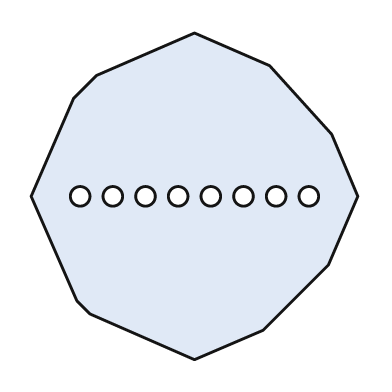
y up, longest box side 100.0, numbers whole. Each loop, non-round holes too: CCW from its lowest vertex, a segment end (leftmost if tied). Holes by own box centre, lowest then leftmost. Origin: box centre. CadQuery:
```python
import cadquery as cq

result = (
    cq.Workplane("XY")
    .moveTo(0.0, -50.0)
    .lineTo(21.0, -41.0)
    .lineTo(41.0, -21.0)
    .lineTo(50.0, 0.0)
    .lineTo(42.0, 19.0)
    .lineTo(23.0, 40.0)
    .lineTo(0.0, 50.0)
    .lineTo(-30.0, 37.0)
    .lineTo(-37.0, 30.0)
    .lineTo(-50.0, 0.0)
    .lineTo(-36.0, -32.0)
    .lineTo(-32.0, -36.0)
    .close()
    .moveTo(-35.0, 0.0)
    .circle(3.0)
    .moveTo(-25.0, 0.0)
    .circle(3.0)
    .moveTo(-15.0, 0.0)
    .circle(3.0)
    .moveTo(-5.0, 0.0)
    .circle(3.0)
    .moveTo(5.0, 0.0)
    .circle(3.0)
    .moveTo(15.0, 0.0)
    .circle(3.0)
    .moveTo(25.0, 0.0)
    .circle(3.0)
    .moveTo(35.0, 0.0)
    .circle(3.0)
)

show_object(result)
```